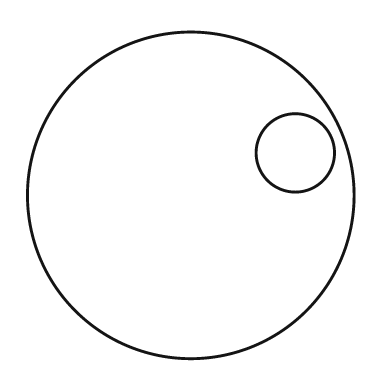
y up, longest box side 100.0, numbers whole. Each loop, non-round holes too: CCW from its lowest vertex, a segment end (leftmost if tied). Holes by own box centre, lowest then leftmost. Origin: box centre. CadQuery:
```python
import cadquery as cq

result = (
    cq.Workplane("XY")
    .moveTo(0.0, 0.0)
    .circle(50.0)
    .moveTo(32.0, 13.0)
    .circle(12.0)
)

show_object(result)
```